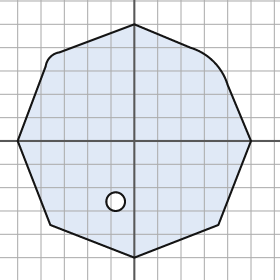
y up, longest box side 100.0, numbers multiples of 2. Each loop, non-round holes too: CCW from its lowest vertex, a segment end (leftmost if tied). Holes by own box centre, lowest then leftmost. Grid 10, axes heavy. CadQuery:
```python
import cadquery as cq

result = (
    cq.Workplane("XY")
    .moveTo(0.0, -50.0)
    .lineTo(36.0, -36.0)
    .lineTo(50.0, 0.0)
    .lineTo(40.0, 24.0)
    .threePointArc((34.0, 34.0), (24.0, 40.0))
    .lineTo(0.0, 50.0)
    .lineTo(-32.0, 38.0)
    .threePointArc((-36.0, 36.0), (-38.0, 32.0))
    .lineTo(-50.0, 0.0)
    .lineTo(-36.0, -36.0)
    .close()
    .moveTo(-8.0, -26.0)
    .circle(4.0)
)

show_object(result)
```